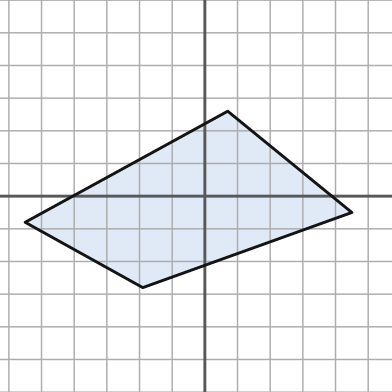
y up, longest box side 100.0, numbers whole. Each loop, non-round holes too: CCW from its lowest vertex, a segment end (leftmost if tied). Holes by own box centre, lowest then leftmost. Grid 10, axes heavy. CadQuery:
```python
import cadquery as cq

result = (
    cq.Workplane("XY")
    .moveTo(-19.0, -28.0)
    .lineTo(45.0, -5.0)
    .lineTo(7.0, 26.0)
    .lineTo(-55.0, -8.0)
    .close()
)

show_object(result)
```